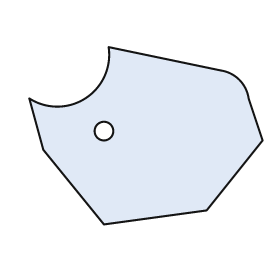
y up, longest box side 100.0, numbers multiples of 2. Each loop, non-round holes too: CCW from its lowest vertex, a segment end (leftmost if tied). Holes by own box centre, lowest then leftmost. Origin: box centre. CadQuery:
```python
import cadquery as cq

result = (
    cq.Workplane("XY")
    .moveTo(-18.0, -38.0)
    .lineTo(26.0, -32.0)
    .lineTo(50.0, -2.0)
    .lineTo(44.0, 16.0)
    .threePointArc((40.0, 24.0), (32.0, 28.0))
    .lineTo(-16.0, 38.0)
    .threePointArc((-26.0, 16.0), (-50.0, 16.0))
    .lineTo(-44.0, -6.0)
    .close()
    .moveTo(-18.0, 2.0)
    .circle(4.0)
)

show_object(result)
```